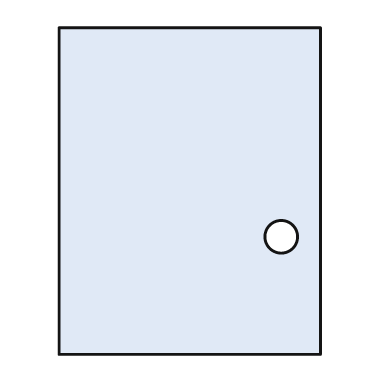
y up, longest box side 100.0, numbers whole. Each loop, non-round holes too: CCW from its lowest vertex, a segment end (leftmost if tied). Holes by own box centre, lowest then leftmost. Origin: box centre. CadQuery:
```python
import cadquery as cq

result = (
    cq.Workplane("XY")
    .moveTo(-40.0, -50.0)
    .lineTo(40.0, -50.0)
    .lineTo(40.0, 50.0)
    .lineTo(-40.0, 50.0)
    .close()
    .moveTo(28.0, -14.0)
    .circle(5.0)
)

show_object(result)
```